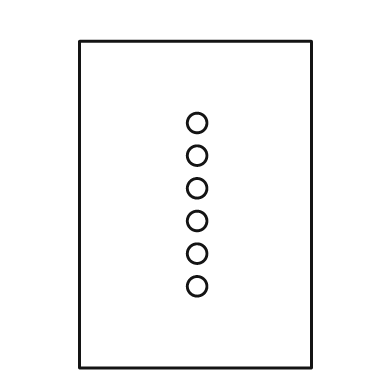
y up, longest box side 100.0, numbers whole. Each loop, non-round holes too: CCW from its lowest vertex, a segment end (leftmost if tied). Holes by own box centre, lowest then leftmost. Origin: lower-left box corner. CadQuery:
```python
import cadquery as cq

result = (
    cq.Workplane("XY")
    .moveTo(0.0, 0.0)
    .lineTo(71.0, 0.0)
    .lineTo(71.0, 100.0)
    .lineTo(0.0, 100.0)
    .close()
    .moveTo(36.0, 25.0)
    .circle(3.0)
    .moveTo(36.0, 35.0)
    .circle(3.0)
    .moveTo(36.0, 45.0)
    .circle(3.0)
    .moveTo(36.0, 55.0)
    .circle(3.0)
    .moveTo(36.0, 65.0)
    .circle(3.0)
    .moveTo(36.0, 75.0)
    .circle(3.0)
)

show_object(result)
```